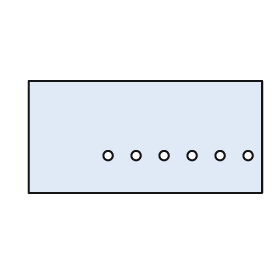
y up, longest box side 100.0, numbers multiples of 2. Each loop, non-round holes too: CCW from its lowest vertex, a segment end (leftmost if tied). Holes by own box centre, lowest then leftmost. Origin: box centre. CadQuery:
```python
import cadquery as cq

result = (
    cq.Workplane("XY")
    .moveTo(-50.0, -24.0)
    .lineTo(50.0, -24.0)
    .lineTo(50.0, 24.0)
    .lineTo(-50.0, 24.0)
    .close()
    .moveTo(-16.0, -8.0)
    .circle(2.0)
    .moveTo(-4.0, -8.0)
    .circle(2.0)
    .moveTo(8.0, -8.0)
    .circle(2.0)
    .moveTo(20.0, -8.0)
    .circle(2.0)
    .moveTo(32.0, -8.0)
    .circle(2.0)
    .moveTo(44.0, -8.0)
    .circle(2.0)
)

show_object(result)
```